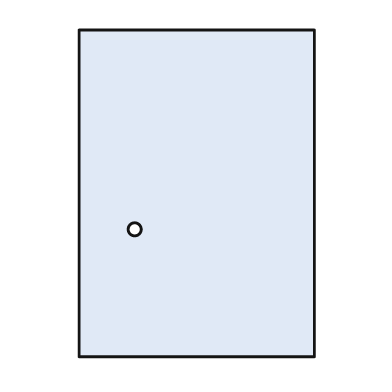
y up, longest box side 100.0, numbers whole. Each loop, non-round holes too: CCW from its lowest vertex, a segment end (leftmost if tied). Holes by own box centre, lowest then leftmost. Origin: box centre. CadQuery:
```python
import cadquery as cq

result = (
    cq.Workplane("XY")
    .moveTo(-36.0, -50.0)
    .lineTo(36.0, -50.0)
    .lineTo(36.0, 50.0)
    .lineTo(-36.0, 50.0)
    .close()
    .moveTo(-19.0, -11.0)
    .circle(2.0)
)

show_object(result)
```